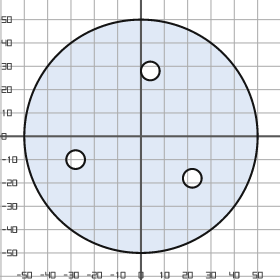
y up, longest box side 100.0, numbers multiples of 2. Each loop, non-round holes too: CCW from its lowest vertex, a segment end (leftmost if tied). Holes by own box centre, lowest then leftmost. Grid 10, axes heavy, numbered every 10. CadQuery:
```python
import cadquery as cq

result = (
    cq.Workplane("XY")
    .moveTo(0.0, 0.0)
    .circle(50.0)
    .moveTo(22.0, -18.0)
    .circle(4.0)
    .moveTo(-28.0, -10.0)
    .circle(4.0)
    .moveTo(4.0, 28.0)
    .circle(4.0)
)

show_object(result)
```